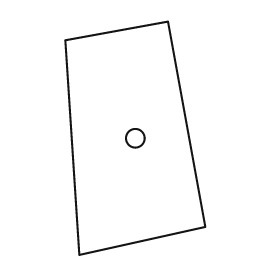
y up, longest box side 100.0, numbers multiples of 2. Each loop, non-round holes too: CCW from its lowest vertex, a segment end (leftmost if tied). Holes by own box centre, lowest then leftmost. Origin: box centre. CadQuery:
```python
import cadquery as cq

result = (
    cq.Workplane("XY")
    .moveTo(-24.0, -50.0)
    .lineTo(30.0, -38.0)
    .lineTo(14.0, 50.0)
    .lineTo(-30.0, 42.0)
    .close()
    .moveTo(0.0, 0.0)
    .circle(4.0)
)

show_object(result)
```